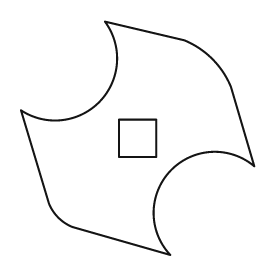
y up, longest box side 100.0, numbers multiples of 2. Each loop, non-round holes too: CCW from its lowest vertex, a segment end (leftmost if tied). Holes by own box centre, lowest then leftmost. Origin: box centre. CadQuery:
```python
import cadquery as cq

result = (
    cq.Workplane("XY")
    .moveTo(14.0, -50.0)
    .threePointArc((14.0, -14.0), (50.0, -12.0))
    .lineTo(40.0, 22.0)
    .threePointArc((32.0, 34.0), (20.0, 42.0))
    .lineTo(-14.0, 50.0)
    .threePointArc((-16.0, 16.0), (-50.0, 12.0))
    .lineTo(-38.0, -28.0)
    .threePointArc((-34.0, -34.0), (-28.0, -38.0))
    .close()
    .moveTo(-8.0, -8.0)
    .lineTo(8.0, -8.0)
    .lineTo(8.0, 8.0)
    .lineTo(-8.0, 8.0)
    .close()
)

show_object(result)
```